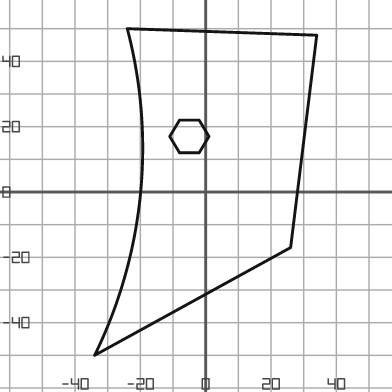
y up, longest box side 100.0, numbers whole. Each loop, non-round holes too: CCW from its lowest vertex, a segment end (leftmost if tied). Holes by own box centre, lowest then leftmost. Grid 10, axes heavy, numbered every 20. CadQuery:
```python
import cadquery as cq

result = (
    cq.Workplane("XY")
    .moveTo(-34.0, -50.0)
    .lineTo(26.0, -17.0)
    .lineTo(34.0, 48.0)
    .lineTo(-24.0, 50.0)
    .threePointArc((-20.0, -1.0), (-34.0, -50.0))
    .close()
    .moveTo(-8.0, 12.0)
    .lineTo(-2.0, 12.0)
    .lineTo(1.0, 17.0)
    .lineTo(-2.0, 22.0)
    .lineTo(-8.0, 22.0)
    .lineTo(-11.0, 17.0)
    .close()
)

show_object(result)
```